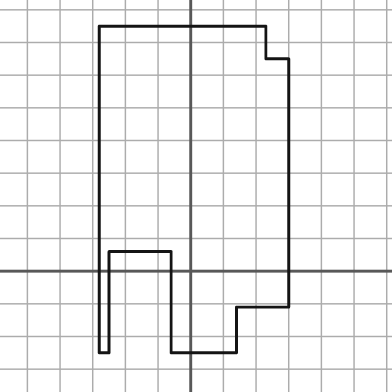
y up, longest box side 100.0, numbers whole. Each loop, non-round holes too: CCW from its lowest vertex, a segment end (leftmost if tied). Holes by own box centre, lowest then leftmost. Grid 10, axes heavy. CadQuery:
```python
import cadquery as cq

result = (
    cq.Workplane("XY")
    .moveTo(-28.0, -25.0)
    .lineTo(-25.0, -25.0)
    .lineTo(-25.0, 6.0)
    .lineTo(-6.0, 6.0)
    .lineTo(-6.0, -25.0)
    .lineTo(14.0, -25.0)
    .lineTo(14.0, -11.0)
    .lineTo(30.0, -11.0)
    .lineTo(30.0, 65.0)
    .lineTo(23.0, 65.0)
    .lineTo(23.0, 75.0)
    .lineTo(-28.0, 75.0)
    .close()
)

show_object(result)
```